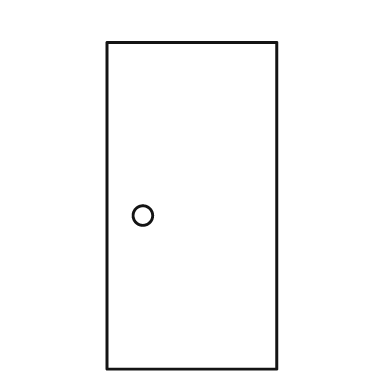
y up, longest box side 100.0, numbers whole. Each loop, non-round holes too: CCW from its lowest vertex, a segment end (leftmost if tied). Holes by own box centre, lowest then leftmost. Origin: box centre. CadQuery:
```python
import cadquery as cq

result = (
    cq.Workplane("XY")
    .moveTo(-26.0, -50.0)
    .lineTo(26.0, -50.0)
    .lineTo(26.0, 50.0)
    .lineTo(-26.0, 50.0)
    .close()
    .moveTo(-15.0, -3.0)
    .circle(3.0)
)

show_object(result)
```